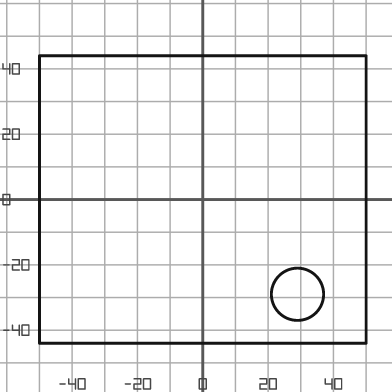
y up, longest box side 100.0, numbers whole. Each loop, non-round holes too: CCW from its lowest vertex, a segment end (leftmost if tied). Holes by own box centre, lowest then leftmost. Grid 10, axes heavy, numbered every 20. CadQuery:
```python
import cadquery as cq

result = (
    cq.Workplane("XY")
    .moveTo(-50.0, -44.0)
    .lineTo(50.0, -44.0)
    .lineTo(50.0, 44.0)
    .lineTo(-50.0, 44.0)
    .close()
    .moveTo(29.0, -29.0)
    .circle(8.0)
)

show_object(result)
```